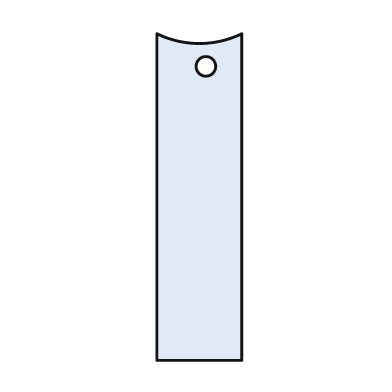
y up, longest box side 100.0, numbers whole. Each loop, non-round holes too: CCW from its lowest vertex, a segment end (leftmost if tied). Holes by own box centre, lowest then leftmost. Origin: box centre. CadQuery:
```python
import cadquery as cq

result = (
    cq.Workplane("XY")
    .moveTo(-13.0, -50.0)
    .lineTo(13.0, -50.0)
    .lineTo(13.0, 50.0)
    .threePointArc((0.0, 47.0), (-13.0, 50.0))
    .close()
    .moveTo(2.0, 40.0)
    .circle(3.0)
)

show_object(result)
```